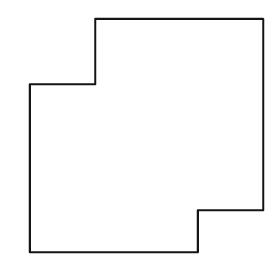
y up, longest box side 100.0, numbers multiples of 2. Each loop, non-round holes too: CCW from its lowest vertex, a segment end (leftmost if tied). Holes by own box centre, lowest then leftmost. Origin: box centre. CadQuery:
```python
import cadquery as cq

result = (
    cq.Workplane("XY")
    .moveTo(-50.0, -50.0)
    .lineTo(22.0, -50.0)
    .lineTo(22.0, -32.0)
    .lineTo(50.0, -32.0)
    .lineTo(50.0, 50.0)
    .lineTo(-22.0, 50.0)
    .lineTo(-22.0, 22.0)
    .lineTo(-50.0, 22.0)
    .close()
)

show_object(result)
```